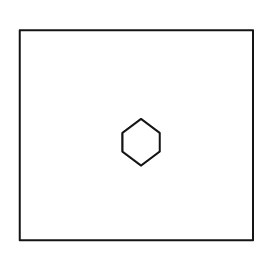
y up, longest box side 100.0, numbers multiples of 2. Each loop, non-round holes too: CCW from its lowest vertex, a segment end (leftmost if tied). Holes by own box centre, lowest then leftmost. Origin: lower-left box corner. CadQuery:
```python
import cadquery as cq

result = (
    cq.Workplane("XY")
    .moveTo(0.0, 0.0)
    .lineTo(100.0, 0.0)
    .lineTo(100.0, 90.0)
    .lineTo(0.0, 90.0)
    .close()
    .moveTo(52.0, 32.0)
    .lineTo(60.0, 38.0)
    .lineTo(60.0, 46.0)
    .lineTo(52.0, 52.0)
    .lineTo(44.0, 46.0)
    .lineTo(44.0, 38.0)
    .close()
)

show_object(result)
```